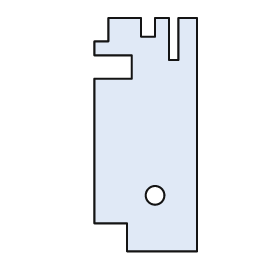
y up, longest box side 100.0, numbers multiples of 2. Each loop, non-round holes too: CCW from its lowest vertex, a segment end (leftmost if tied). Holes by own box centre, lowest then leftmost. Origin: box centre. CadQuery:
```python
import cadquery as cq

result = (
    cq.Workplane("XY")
    .moveTo(-8.0, -50.0)
    .lineTo(22.0, -50.0)
    .lineTo(22.0, 50.0)
    .lineTo(14.0, 50.0)
    .lineTo(14.0, 32.0)
    .lineTo(10.0, 32.0)
    .lineTo(10.0, 50.0)
    .lineTo(4.0, 50.0)
    .lineTo(4.0, 42.0)
    .lineTo(-2.0, 42.0)
    .lineTo(-2.0, 50.0)
    .lineTo(-16.0, 50.0)
    .lineTo(-16.0, 40.0)
    .lineTo(-22.0, 40.0)
    .lineTo(-22.0, 34.0)
    .lineTo(-6.0, 34.0)
    .lineTo(-6.0, 24.0)
    .lineTo(-22.0, 24.0)
    .lineTo(-22.0, -38.0)
    .lineTo(-8.0, -38.0)
    .close()
    .moveTo(4.0, -26.0)
    .circle(4.0)
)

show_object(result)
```